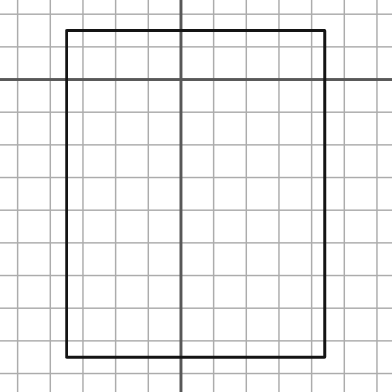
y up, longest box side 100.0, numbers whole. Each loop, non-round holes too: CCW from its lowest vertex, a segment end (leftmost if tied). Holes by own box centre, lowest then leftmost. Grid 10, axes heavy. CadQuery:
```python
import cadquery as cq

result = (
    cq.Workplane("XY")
    .moveTo(-35.0, -85.0)
    .lineTo(44.0, -85.0)
    .lineTo(44.0, 15.0)
    .lineTo(-35.0, 15.0)
    .close()
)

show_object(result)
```